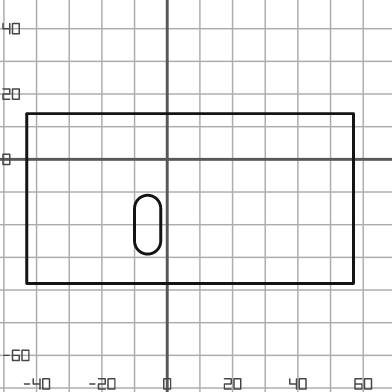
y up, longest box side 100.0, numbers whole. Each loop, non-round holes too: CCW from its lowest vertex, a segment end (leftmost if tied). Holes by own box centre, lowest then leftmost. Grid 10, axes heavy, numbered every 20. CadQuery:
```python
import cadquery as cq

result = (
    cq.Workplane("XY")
    .moveTo(-43.0, -38.0)
    .lineTo(57.0, -38.0)
    .lineTo(57.0, 14.0)
    .lineTo(-43.0, 14.0)
    .close()
    .moveTo(-10.0, -25.0)
    .threePointArc((-6.0, -29.0), (-2.0, -25.0))
    .lineTo(-2.0, -15.0)
    .threePointArc((-6.0, -11.0), (-10.0, -15.0))
    .close()
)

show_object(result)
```